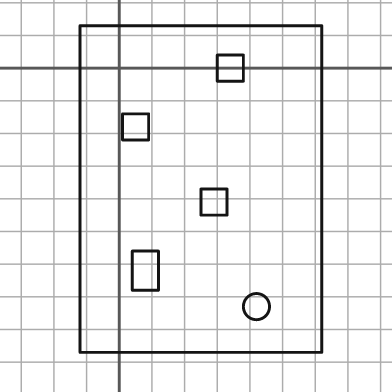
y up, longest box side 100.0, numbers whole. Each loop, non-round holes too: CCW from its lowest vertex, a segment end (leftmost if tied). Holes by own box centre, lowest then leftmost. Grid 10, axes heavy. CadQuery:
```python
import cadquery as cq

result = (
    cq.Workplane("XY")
    .moveTo(-12.0, -87.0)
    .lineTo(62.0, -87.0)
    .lineTo(62.0, 13.0)
    .lineTo(-12.0, 13.0)
    .close()
    .moveTo(42.0, -73.0)
    .circle(4.0)
    .moveTo(4.0, -68.0)
    .lineTo(12.0, -68.0)
    .lineTo(12.0, -56.0)
    .lineTo(4.0, -56.0)
    .close()
    .moveTo(25.0, -45.0)
    .lineTo(33.0, -45.0)
    .lineTo(33.0, -37.0)
    .lineTo(25.0, -37.0)
    .close()
    .moveTo(1.0, -22.0)
    .lineTo(9.0, -22.0)
    .lineTo(9.0, -14.0)
    .lineTo(1.0, -14.0)
    .close()
    .moveTo(30.0, -4.0)
    .lineTo(38.0, -4.0)
    .lineTo(38.0, 4.0)
    .lineTo(30.0, 4.0)
    .close()
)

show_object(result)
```